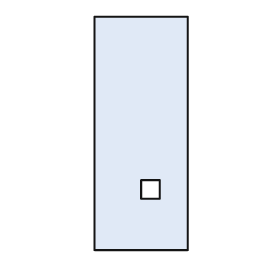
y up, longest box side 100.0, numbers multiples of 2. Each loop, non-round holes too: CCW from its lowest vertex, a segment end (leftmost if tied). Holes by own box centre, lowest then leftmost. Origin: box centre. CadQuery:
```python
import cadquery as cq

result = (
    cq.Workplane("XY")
    .moveTo(-20.0, -50.0)
    .lineTo(20.0, -50.0)
    .lineTo(20.0, 50.0)
    .lineTo(-20.0, 50.0)
    .close()
    .moveTo(0.0, -28.0)
    .lineTo(8.0, -28.0)
    .lineTo(8.0, -20.0)
    .lineTo(0.0, -20.0)
    .close()
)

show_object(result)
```